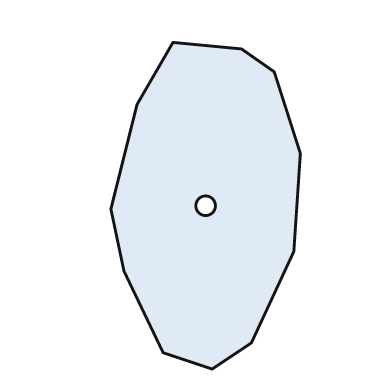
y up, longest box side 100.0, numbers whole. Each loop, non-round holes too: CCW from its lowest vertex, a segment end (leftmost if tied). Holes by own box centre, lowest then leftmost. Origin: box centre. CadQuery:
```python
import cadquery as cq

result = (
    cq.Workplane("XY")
    .moveTo(2.0, -50.0)
    .lineTo(14.0, -42.0)
    .lineTo(27.0, -14.0)
    .lineTo(29.0, 16.0)
    .lineTo(21.0, 41.0)
    .lineTo(11.0, 48.0)
    .lineTo(-10.0, 50.0)
    .lineTo(-21.0, 31.0)
    .lineTo(-29.0, -1.0)
    .lineTo(-25.0, -20.0)
    .lineTo(-13.0, -45.0)
    .close()
    .moveTo(0.0, 0.0)
    .circle(3.0)
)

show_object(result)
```